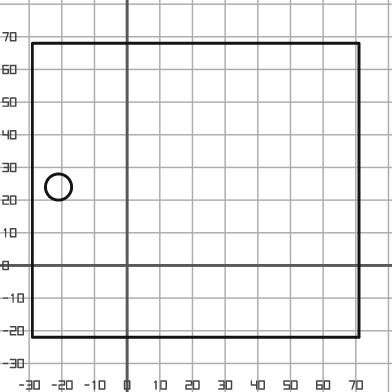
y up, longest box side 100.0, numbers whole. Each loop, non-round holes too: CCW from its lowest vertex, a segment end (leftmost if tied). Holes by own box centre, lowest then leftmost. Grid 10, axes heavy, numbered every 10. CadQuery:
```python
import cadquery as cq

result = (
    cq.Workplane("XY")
    .moveTo(-29.0, -22.0)
    .lineTo(71.0, -22.0)
    .lineTo(71.0, 68.0)
    .lineTo(-29.0, 68.0)
    .close()
    .moveTo(-21.0, 24.0)
    .circle(4.0)
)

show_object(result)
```